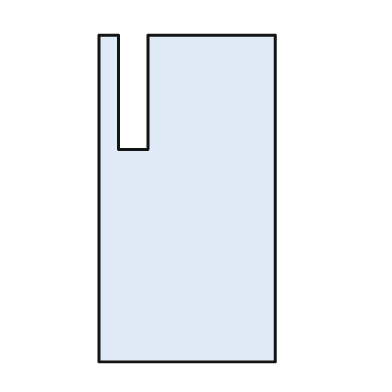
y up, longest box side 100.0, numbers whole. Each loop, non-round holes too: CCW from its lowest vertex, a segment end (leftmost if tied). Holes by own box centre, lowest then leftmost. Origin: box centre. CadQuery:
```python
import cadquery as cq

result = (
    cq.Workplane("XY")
    .moveTo(-27.0, -50.0)
    .lineTo(27.0, -50.0)
    .lineTo(27.0, 50.0)
    .lineTo(-12.0, 50.0)
    .lineTo(-12.0, 15.0)
    .lineTo(-21.0, 15.0)
    .lineTo(-21.0, 50.0)
    .lineTo(-27.0, 50.0)
    .close()
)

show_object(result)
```